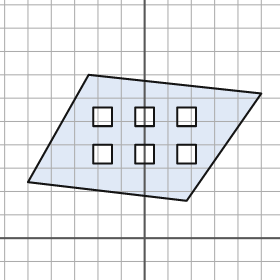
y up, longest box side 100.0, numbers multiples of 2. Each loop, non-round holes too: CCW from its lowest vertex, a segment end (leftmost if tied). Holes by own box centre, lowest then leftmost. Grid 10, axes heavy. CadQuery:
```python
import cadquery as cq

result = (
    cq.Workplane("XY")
    .moveTo(18.0, 16.0)
    .lineTo(50.0, 62.0)
    .lineTo(-24.0, 70.0)
    .lineTo(-50.0, 24.0)
    .close()
    .moveTo(-22.0, 32.0)
    .lineTo(-14.0, 32.0)
    .lineTo(-14.0, 40.0)
    .lineTo(-22.0, 40.0)
    .close()
    .moveTo(-4.0, 32.0)
    .lineTo(4.0, 32.0)
    .lineTo(4.0, 40.0)
    .lineTo(-4.0, 40.0)
    .close()
    .moveTo(14.0, 32.0)
    .lineTo(22.0, 32.0)
    .lineTo(22.0, 40.0)
    .lineTo(14.0, 40.0)
    .close()
    .moveTo(-22.0, 48.0)
    .lineTo(-14.0, 48.0)
    .lineTo(-14.0, 56.0)
    .lineTo(-22.0, 56.0)
    .close()
    .moveTo(-4.0, 48.0)
    .lineTo(4.0, 48.0)
    .lineTo(4.0, 56.0)
    .lineTo(-4.0, 56.0)
    .close()
    .moveTo(14.0, 48.0)
    .lineTo(22.0, 48.0)
    .lineTo(22.0, 56.0)
    .lineTo(14.0, 56.0)
    .close()
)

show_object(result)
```